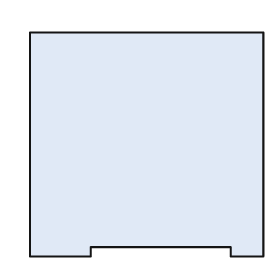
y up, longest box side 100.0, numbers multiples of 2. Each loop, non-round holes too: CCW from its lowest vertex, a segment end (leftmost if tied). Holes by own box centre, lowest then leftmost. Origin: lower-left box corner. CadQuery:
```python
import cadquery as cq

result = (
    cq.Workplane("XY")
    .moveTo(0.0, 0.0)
    .lineTo(26.0, 0.0)
    .lineTo(26.0, 4.0)
    .lineTo(86.0, 4.0)
    .lineTo(86.0, 0.0)
    .lineTo(100.0, 0.0)
    .lineTo(100.0, 96.0)
    .lineTo(0.0, 96.0)
    .close()
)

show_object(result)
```